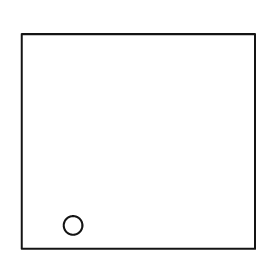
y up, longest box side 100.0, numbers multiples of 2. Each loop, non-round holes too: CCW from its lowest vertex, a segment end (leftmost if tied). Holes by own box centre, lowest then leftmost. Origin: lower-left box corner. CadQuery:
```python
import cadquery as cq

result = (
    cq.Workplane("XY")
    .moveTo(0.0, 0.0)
    .lineTo(100.0, 0.0)
    .lineTo(100.0, 92.0)
    .lineTo(0.0, 92.0)
    .close()
    .moveTo(22.0, 10.0)
    .circle(4.0)
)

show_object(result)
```